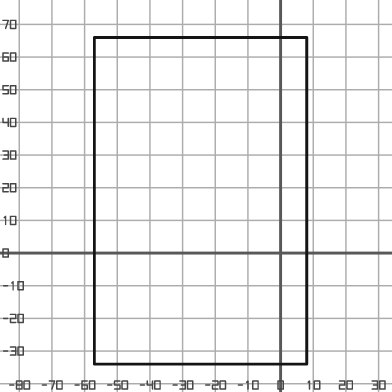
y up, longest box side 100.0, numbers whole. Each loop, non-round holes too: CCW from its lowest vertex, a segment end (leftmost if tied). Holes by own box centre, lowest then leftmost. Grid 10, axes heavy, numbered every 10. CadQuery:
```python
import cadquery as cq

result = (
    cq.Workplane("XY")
    .moveTo(-57.0, -34.0)
    .lineTo(8.0, -34.0)
    .lineTo(8.0, 66.0)
    .lineTo(-57.0, 66.0)
    .close()
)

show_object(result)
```